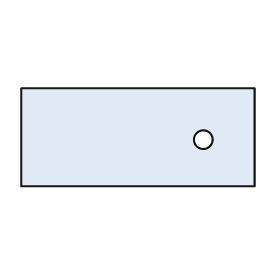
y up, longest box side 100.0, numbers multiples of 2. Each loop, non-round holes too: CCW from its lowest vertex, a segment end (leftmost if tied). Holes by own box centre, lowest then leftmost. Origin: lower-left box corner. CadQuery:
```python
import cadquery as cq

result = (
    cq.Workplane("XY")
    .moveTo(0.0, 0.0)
    .lineTo(100.0, 0.0)
    .lineTo(100.0, 42.0)
    .lineTo(0.0, 42.0)
    .close()
    .moveTo(78.0, 20.0)
    .circle(4.0)
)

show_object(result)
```